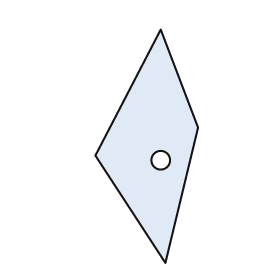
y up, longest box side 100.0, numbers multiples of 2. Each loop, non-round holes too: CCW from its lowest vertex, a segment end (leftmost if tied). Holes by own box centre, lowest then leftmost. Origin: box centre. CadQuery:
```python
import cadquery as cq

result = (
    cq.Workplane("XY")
    .moveTo(8.0, -50.0)
    .lineTo(22.0, 8.0)
    .lineTo(6.0, 50.0)
    .lineTo(-22.0, -4.0)
    .close()
    .moveTo(6.0, -6.0)
    .circle(4.0)
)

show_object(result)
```